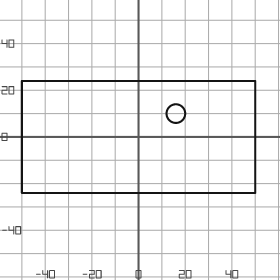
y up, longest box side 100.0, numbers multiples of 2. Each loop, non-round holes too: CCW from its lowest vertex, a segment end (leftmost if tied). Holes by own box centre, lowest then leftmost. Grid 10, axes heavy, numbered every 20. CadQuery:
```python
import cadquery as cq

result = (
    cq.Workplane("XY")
    .moveTo(-50.0, -24.0)
    .lineTo(50.0, -24.0)
    .lineTo(50.0, 24.0)
    .lineTo(-50.0, 24.0)
    .close()
    .moveTo(16.0, 10.0)
    .circle(4.0)
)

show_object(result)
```